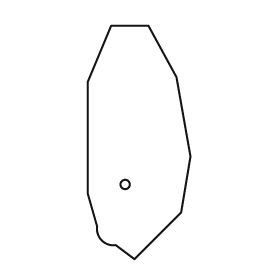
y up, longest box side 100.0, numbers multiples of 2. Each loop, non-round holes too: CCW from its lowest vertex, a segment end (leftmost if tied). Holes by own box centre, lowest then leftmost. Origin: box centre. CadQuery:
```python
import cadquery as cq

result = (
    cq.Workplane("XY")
    .moveTo(-2.0, -50.0)
    .lineTo(18.0, -30.0)
    .lineTo(22.0, -6.0)
    .lineTo(16.0, 28.0)
    .lineTo(4.0, 50.0)
    .lineTo(-12.0, 50.0)
    .lineTo(-22.0, 26.0)
    .lineTo(-22.0, -22.0)
    .lineTo(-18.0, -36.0)
    .threePointArc((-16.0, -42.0), (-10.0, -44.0))
    .close()
    .moveTo(-6.0, -18.0)
    .circle(2.0)
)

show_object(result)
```